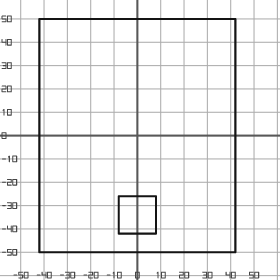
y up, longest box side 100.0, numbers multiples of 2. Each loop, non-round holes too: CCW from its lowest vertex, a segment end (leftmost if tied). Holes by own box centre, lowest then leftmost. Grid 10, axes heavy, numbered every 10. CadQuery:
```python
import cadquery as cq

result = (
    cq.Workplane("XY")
    .moveTo(-42.0, -50.0)
    .lineTo(42.0, -50.0)
    .lineTo(42.0, 50.0)
    .lineTo(-42.0, 50.0)
    .close()
    .moveTo(-8.0, -42.0)
    .lineTo(8.0, -42.0)
    .lineTo(8.0, -26.0)
    .lineTo(-8.0, -26.0)
    .close()
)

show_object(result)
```